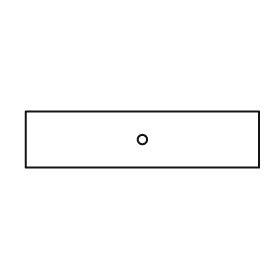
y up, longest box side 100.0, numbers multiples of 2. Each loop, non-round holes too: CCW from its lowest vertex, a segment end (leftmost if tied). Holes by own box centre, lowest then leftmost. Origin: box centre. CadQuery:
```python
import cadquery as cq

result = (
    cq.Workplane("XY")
    .moveTo(-50.0, -12.0)
    .lineTo(50.0, -12.0)
    .lineTo(50.0, 12.0)
    .lineTo(-50.0, 12.0)
    .close()
    .moveTo(0.0, 0.0)
    .circle(2.0)
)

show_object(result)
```